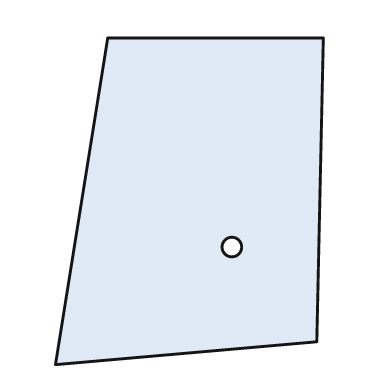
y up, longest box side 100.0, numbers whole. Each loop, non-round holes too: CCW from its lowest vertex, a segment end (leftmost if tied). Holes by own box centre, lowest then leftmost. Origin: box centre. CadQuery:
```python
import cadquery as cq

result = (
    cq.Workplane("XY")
    .moveTo(-41.0, -50.0)
    .lineTo(39.0, -43.0)
    .lineTo(41.0, 50.0)
    .lineTo(-25.0, 50.0)
    .close()
    .moveTo(13.0, -14.0)
    .circle(3.0)
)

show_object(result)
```